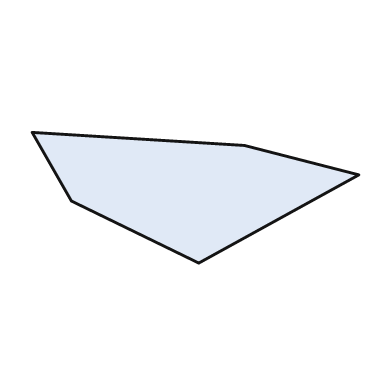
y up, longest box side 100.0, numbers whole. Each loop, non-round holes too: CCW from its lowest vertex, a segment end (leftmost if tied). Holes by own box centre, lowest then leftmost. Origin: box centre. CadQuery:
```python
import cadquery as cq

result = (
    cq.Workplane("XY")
    .moveTo(1.0, -20.0)
    .lineTo(50.0, 7.0)
    .lineTo(15.0, 16.0)
    .lineTo(-50.0, 20.0)
    .lineTo(-38.0, -1.0)
    .close()
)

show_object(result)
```